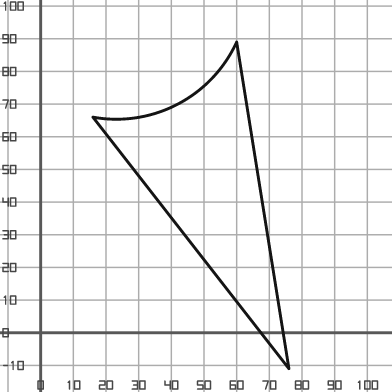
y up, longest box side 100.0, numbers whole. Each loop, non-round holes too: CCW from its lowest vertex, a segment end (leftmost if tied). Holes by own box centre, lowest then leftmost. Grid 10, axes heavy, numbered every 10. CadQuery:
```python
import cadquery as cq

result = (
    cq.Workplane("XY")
    .moveTo(76.0, -11.0)
    .lineTo(60.0, 89.0)
    .threePointArc((42.0, 70.0), (16.0, 66.0))
    .close()
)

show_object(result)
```